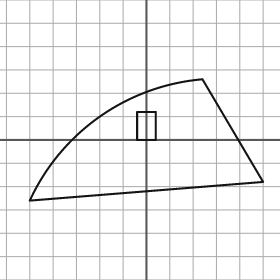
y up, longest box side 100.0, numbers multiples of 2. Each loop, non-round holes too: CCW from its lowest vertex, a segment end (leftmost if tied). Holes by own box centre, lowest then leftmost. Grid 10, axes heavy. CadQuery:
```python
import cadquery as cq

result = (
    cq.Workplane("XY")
    .moveTo(-50.0, -26.0)
    .lineTo(50.0, -18.0)
    .lineTo(24.0, 26.0)
    .threePointArc((-20.0, 10.0), (-50.0, -26.0))
    .close()
    .moveTo(-4.0, 0.0)
    .lineTo(4.0, 0.0)
    .lineTo(4.0, 12.0)
    .lineTo(-4.0, 12.0)
    .close()
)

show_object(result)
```